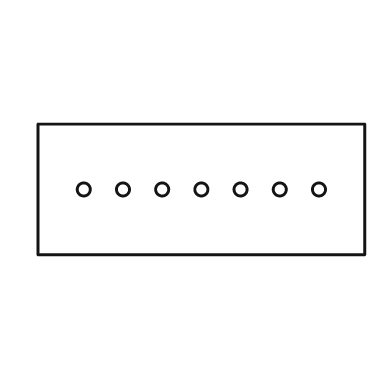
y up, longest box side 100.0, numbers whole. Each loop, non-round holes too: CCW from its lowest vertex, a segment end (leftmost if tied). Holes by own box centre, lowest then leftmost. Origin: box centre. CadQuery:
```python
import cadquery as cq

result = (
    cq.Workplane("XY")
    .moveTo(-50.0, -20.0)
    .lineTo(50.0, -20.0)
    .lineTo(50.0, 20.0)
    .lineTo(-50.0, 20.0)
    .close()
    .moveTo(-36.0, 0.0)
    .circle(2.0)
    .moveTo(-24.0, 0.0)
    .circle(2.0)
    .moveTo(-12.0, 0.0)
    .circle(2.0)
    .moveTo(0.0, 0.0)
    .circle(2.0)
    .moveTo(12.0, 0.0)
    .circle(2.0)
    .moveTo(24.0, 0.0)
    .circle(2.0)
    .moveTo(36.0, 0.0)
    .circle(2.0)
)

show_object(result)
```